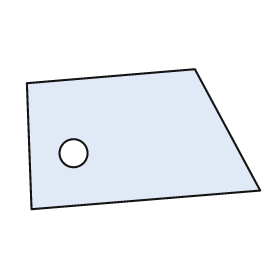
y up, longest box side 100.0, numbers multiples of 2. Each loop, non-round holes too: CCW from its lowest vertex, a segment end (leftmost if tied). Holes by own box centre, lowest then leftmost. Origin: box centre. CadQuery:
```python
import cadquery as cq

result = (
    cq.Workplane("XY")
    .moveTo(-48.0, -30.0)
    .lineTo(50.0, -22.0)
    .lineTo(22.0, 30.0)
    .lineTo(-50.0, 24.0)
    .close()
    .moveTo(-30.0, -6.0)
    .circle(6.0)
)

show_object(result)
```